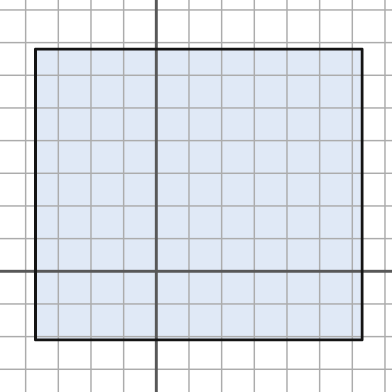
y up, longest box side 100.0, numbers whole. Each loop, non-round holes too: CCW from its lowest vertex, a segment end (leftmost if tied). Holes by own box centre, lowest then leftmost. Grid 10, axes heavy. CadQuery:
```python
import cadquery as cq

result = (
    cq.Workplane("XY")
    .moveTo(-37.0, -21.0)
    .lineTo(63.0, -21.0)
    .lineTo(63.0, 68.0)
    .lineTo(-37.0, 68.0)
    .close()
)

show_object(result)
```